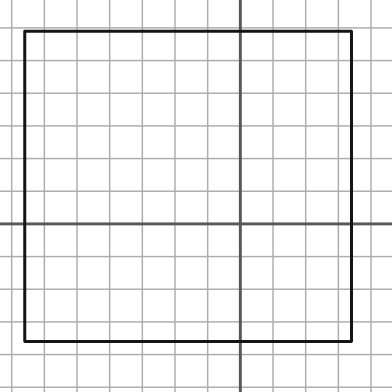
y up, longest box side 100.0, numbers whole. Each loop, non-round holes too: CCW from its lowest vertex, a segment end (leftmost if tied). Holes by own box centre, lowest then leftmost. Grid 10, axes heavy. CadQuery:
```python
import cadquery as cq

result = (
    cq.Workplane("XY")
    .moveTo(-66.0, -36.0)
    .lineTo(34.0, -36.0)
    .lineTo(34.0, 59.0)
    .lineTo(-66.0, 59.0)
    .close()
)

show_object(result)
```